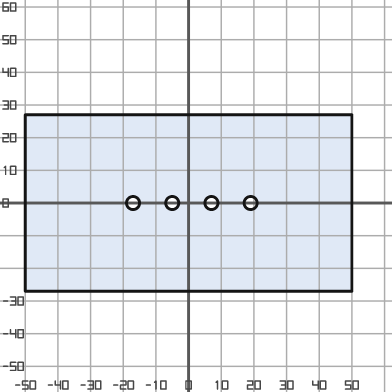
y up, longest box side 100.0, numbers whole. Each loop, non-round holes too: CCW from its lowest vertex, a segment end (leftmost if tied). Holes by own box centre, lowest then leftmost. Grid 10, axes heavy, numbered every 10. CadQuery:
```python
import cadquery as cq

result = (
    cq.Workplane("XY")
    .moveTo(-50.0, -27.0)
    .lineTo(50.0, -27.0)
    .lineTo(50.0, 27.0)
    .lineTo(-50.0, 27.0)
    .close()
    .moveTo(-17.0, 0.0)
    .circle(2.0)
    .moveTo(-5.0, 0.0)
    .circle(2.0)
    .moveTo(7.0, 0.0)
    .circle(2.0)
    .moveTo(19.0, 0.0)
    .circle(2.0)
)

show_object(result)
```